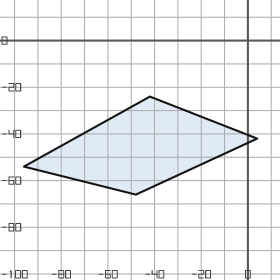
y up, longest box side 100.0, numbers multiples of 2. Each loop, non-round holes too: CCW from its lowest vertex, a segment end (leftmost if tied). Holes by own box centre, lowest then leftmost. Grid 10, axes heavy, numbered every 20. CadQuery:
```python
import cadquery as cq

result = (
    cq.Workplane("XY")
    .moveTo(-48.0, -66.0)
    .lineTo(4.0, -42.0)
    .lineTo(-42.0, -24.0)
    .lineTo(-96.0, -54.0)
    .close()
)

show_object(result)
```